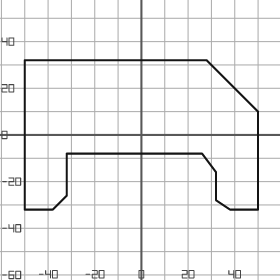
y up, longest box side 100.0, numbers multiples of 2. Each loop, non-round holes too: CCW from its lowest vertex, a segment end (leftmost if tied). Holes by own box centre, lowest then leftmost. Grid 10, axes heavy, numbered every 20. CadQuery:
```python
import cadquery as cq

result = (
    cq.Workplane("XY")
    .moveTo(-50.0, -32.0)
    .lineTo(-38.0, -32.0)
    .lineTo(-32.0, -26.0)
    .lineTo(-32.0, -8.0)
    .lineTo(26.0, -8.0)
    .lineTo(32.0, -16.0)
    .lineTo(32.0, -28.0)
    .lineTo(38.0, -32.0)
    .lineTo(50.0, -32.0)
    .lineTo(50.0, 10.0)
    .lineTo(28.0, 32.0)
    .lineTo(-50.0, 32.0)
    .close()
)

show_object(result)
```